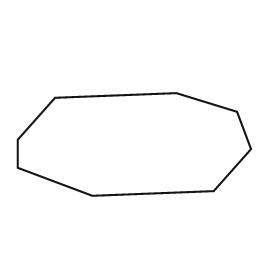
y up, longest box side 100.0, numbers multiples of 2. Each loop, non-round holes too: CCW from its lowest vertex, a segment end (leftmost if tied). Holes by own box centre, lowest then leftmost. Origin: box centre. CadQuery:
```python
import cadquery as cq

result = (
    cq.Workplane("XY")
    .moveTo(-18.0, -22.0)
    .lineTo(34.0, -20.0)
    .lineTo(50.0, -2.0)
    .lineTo(44.0, 14.0)
    .lineTo(18.0, 22.0)
    .lineTo(-34.0, 20.0)
    .lineTo(-50.0, 2.0)
    .lineTo(-50.0, -10.0)
    .close()
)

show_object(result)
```